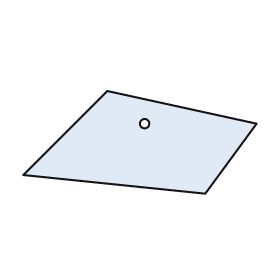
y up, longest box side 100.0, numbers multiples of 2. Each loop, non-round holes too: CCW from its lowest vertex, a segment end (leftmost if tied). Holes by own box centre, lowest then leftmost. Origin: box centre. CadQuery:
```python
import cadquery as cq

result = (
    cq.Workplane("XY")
    .moveTo(28.0, -22.0)
    .lineTo(50.0, 8.0)
    .lineTo(-14.0, 22.0)
    .lineTo(-50.0, -14.0)
    .close()
    .moveTo(2.0, 8.0)
    .circle(2.0)
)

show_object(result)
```